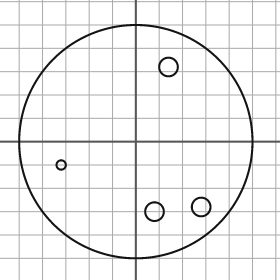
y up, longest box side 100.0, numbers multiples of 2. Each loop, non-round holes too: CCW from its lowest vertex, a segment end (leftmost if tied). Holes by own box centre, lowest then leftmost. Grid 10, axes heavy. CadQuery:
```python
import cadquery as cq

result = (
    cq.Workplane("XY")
    .moveTo(0.0, 0.0)
    .circle(50.0)
    .moveTo(8.0, -30.0)
    .circle(4.0)
    .moveTo(28.0, -28.0)
    .circle(4.0)
    .moveTo(-32.0, -10.0)
    .circle(2.0)
    .moveTo(14.0, 32.0)
    .circle(4.0)
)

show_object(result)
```